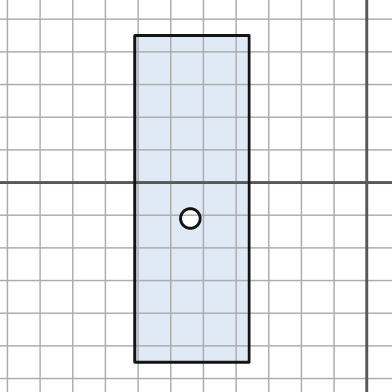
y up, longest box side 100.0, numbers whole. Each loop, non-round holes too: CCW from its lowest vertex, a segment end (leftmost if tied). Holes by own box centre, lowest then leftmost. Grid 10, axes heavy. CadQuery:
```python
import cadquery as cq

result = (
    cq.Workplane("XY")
    .moveTo(-71.0, -55.0)
    .lineTo(-36.0, -55.0)
    .lineTo(-36.0, 45.0)
    .lineTo(-71.0, 45.0)
    .close()
    .moveTo(-54.0, -11.0)
    .circle(3.0)
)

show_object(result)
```